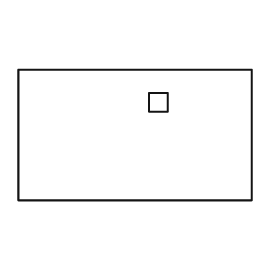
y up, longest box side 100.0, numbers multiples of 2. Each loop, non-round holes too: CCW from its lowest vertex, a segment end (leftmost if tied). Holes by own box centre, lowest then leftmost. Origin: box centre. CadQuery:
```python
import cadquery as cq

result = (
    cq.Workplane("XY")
    .moveTo(-50.0, -28.0)
    .lineTo(50.0, -28.0)
    .lineTo(50.0, 28.0)
    .lineTo(-50.0, 28.0)
    .close()
    .moveTo(6.0, 10.0)
    .lineTo(14.0, 10.0)
    .lineTo(14.0, 18.0)
    .lineTo(6.0, 18.0)
    .close()
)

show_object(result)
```